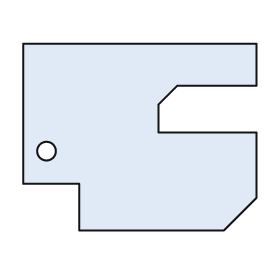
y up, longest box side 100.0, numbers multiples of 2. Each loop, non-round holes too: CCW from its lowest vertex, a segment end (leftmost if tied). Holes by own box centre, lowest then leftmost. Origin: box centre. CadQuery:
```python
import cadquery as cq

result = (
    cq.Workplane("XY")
    .moveTo(-26.0, -40.0)
    .lineTo(36.0, -40.0)
    .lineTo(50.0, -26.0)
    .lineTo(50.0, 2.0)
    .lineTo(8.0, 2.0)
    .lineTo(8.0, 14.0)
    .lineTo(16.0, 22.0)
    .lineTo(50.0, 22.0)
    .lineTo(50.0, 40.0)
    .lineTo(-50.0, 40.0)
    .lineTo(-50.0, -20.0)
    .lineTo(-26.0, -20.0)
    .close()
    .moveTo(-40.0, -6.0)
    .circle(4.0)
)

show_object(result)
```